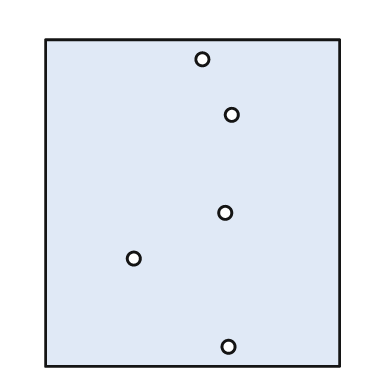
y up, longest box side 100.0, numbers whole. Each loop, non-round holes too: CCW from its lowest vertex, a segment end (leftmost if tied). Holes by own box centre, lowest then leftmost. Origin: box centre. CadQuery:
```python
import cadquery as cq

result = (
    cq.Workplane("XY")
    .moveTo(-45.0, -50.0)
    .lineTo(45.0, -50.0)
    .lineTo(45.0, 50.0)
    .lineTo(-45.0, 50.0)
    .close()
    .moveTo(11.0, -44.0)
    .circle(2.0)
    .moveTo(-18.0, -17.0)
    .circle(2.0)
    .moveTo(10.0, -3.0)
    .circle(2.0)
    .moveTo(12.0, 27.0)
    .circle(2.0)
    .moveTo(3.0, 44.0)
    .circle(2.0)
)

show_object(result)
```